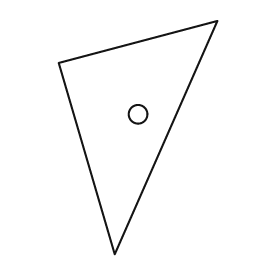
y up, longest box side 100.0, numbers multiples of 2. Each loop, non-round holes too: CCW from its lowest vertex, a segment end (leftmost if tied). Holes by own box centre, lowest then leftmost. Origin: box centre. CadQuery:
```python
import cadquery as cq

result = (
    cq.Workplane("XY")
    .moveTo(-10.0, -50.0)
    .lineTo(34.0, 50.0)
    .lineTo(-34.0, 32.0)
    .close()
    .moveTo(0.0, 10.0)
    .circle(4.0)
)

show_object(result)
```